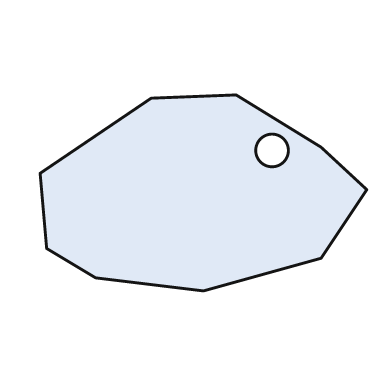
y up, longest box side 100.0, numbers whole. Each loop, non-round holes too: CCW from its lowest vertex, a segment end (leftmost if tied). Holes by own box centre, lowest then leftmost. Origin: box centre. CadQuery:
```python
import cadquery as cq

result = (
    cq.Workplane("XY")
    .moveTo(0.0, -30.0)
    .lineTo(36.0, -20.0)
    .lineTo(50.0, 1.0)
    .lineTo(36.0, 14.0)
    .lineTo(10.0, 30.0)
    .lineTo(-16.0, 29.0)
    .lineTo(-50.0, 6.0)
    .lineTo(-48.0, -17.0)
    .lineTo(-33.0, -26.0)
    .close()
    .moveTo(21.0, 13.0)
    .circle(5.0)
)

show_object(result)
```